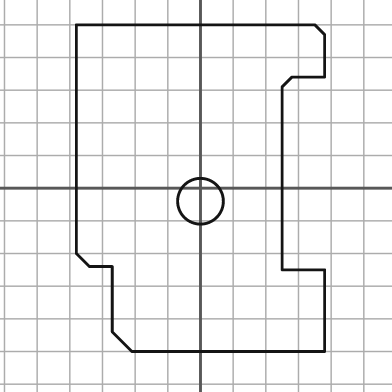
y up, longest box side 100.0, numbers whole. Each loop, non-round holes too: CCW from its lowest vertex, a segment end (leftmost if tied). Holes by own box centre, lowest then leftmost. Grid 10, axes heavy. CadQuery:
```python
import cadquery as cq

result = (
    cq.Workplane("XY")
    .moveTo(-21.0, -50.0)
    .lineTo(38.0, -50.0)
    .lineTo(38.0, -25.0)
    .lineTo(25.0, -25.0)
    .lineTo(25.0, 31.0)
    .lineTo(28.0, 34.0)
    .lineTo(38.0, 34.0)
    .lineTo(38.0, 47.0)
    .lineTo(35.0, 50.0)
    .lineTo(-38.0, 50.0)
    .lineTo(-38.0, -20.0)
    .lineTo(-34.0, -24.0)
    .lineTo(-27.0, -24.0)
    .lineTo(-27.0, -44.0)
    .close()
    .moveTo(0.0, -4.0)
    .circle(7.0)
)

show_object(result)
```